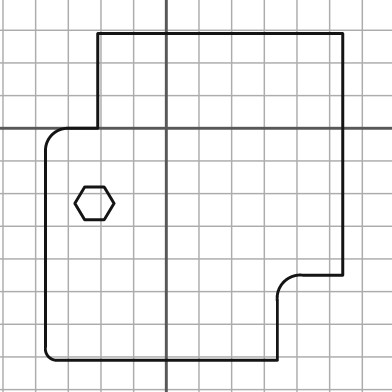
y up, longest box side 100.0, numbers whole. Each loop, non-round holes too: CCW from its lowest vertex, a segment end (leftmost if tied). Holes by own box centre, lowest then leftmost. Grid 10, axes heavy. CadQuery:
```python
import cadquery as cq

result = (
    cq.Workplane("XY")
    .moveTo(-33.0, -71.0)
    .lineTo(34.0, -71.0)
    .lineTo(34.0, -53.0)
    .threePointArc((36.0, -47.0), (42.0, -45.0))
    .lineTo(54.0, -45.0)
    .lineTo(54.0, 29.0)
    .lineTo(-21.0, 29.0)
    .lineTo(-21.0, 0.0)
    .lineTo(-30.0, 0.0)
    .threePointArc((-35.0, -2.0), (-37.0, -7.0))
    .lineTo(-37.0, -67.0)
    .threePointArc((-36.0, -70.0), (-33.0, -71.0))
    .close()
    .moveTo(-25.0, -28.0)
    .lineTo(-19.0, -28.0)
    .lineTo(-16.0, -23.0)
    .lineTo(-19.0, -18.0)
    .lineTo(-25.0, -18.0)
    .lineTo(-28.0, -23.0)
    .close()
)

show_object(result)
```